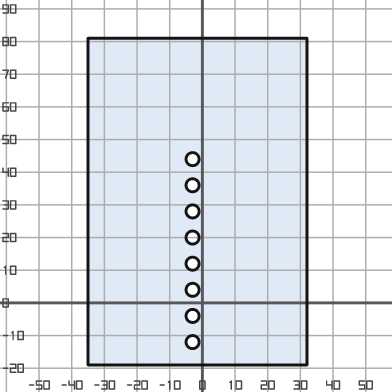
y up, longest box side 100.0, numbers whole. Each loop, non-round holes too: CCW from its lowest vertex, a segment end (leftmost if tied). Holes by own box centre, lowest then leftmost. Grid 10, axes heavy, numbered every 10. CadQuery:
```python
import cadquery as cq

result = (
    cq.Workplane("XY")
    .moveTo(-35.0, -19.0)
    .lineTo(32.0, -19.0)
    .lineTo(32.0, 81.0)
    .lineTo(-35.0, 81.0)
    .close()
    .moveTo(-3.0, -12.0)
    .circle(2.0)
    .moveTo(-3.0, -4.0)
    .circle(2.0)
    .moveTo(-3.0, 4.0)
    .circle(2.0)
    .moveTo(-3.0, 12.0)
    .circle(2.0)
    .moveTo(-3.0, 20.0)
    .circle(2.0)
    .moveTo(-3.0, 28.0)
    .circle(2.0)
    .moveTo(-3.0, 36.0)
    .circle(2.0)
    .moveTo(-3.0, 44.0)
    .circle(2.0)
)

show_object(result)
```